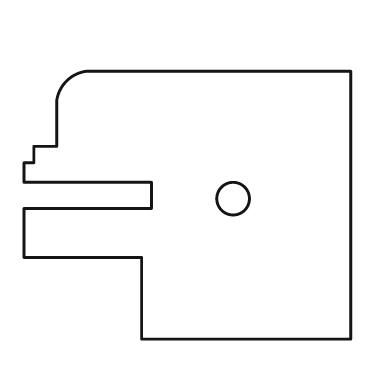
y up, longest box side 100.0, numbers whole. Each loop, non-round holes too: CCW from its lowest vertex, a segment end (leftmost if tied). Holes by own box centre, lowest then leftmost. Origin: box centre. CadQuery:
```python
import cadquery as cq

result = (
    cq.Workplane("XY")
    .moveTo(-14.0, -41.0)
    .lineTo(50.0, -41.0)
    .lineTo(50.0, 41.0)
    .lineTo(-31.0, 41.0)
    .threePointArc((-37.0, 38.0), (-40.0, 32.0))
    .lineTo(-40.0, 18.0)
    .lineTo(-47.0, 18.0)
    .lineTo(-47.0, 13.0)
    .lineTo(-50.0, 13.0)
    .lineTo(-50.0, 7.0)
    .lineTo(-11.0, 7.0)
    .lineTo(-11.0, -1.0)
    .lineTo(-50.0, -1.0)
    .lineTo(-50.0, -16.0)
    .lineTo(-14.0, -16.0)
    .close()
    .moveTo(14.0, 2.0)
    .circle(5.0)
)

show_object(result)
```